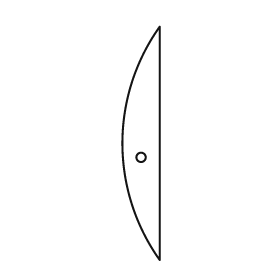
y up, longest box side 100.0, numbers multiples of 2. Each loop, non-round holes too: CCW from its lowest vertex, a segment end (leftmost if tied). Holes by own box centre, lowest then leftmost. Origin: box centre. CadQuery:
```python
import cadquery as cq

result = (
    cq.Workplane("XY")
    .moveTo(8.0, -50.0)
    .lineTo(8.0, 50.0)
    .threePointArc((-8.0, 0.0), (8.0, -50.0))
    .close()
    .moveTo(0.0, -6.0)
    .circle(2.0)
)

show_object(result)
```